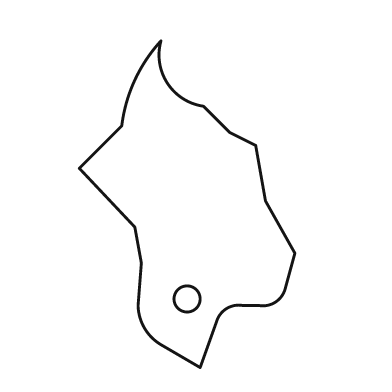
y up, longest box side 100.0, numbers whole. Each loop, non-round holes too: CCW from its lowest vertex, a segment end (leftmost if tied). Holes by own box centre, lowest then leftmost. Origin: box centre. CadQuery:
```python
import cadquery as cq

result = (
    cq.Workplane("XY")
    .moveTo(4.0, -50.0)
    .lineTo(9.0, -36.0)
    .threePointArc((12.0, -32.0), (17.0, -31.0))
    .lineTo(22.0, -31.0)
    .threePointArc((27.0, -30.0), (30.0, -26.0))
    .lineTo(33.0, -15.0)
    .lineTo(24.0, 1.0)
    .lineTo(21.0, 18.0)
    .lineTo(13.0, 22.0)
    .lineTo(5.0, 30.0)
    .threePointArc((-6.0, 37.0), (-8.0, 50.0))
    .threePointArc((-16.0, 38.0), (-20.0, 24.0))
    .lineTo(-33.0, 11.0)
    .lineTo(-16.0, -7.0)
    .lineTo(-14.0, -18.0)
    .lineTo(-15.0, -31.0)
    .threePointArc((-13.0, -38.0), (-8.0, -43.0))
    .close()
    .moveTo(0.0, -29.0)
    .circle(4.0)
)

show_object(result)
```